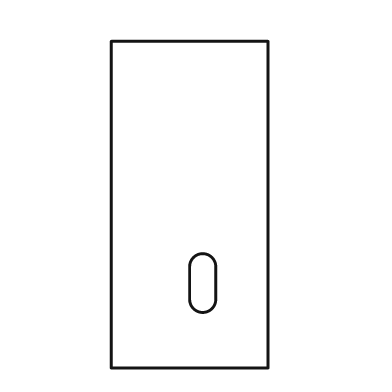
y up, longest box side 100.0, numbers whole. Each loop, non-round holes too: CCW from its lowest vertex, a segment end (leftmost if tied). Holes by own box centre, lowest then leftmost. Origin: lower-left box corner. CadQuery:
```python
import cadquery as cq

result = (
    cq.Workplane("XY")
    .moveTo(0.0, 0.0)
    .lineTo(48.0, 0.0)
    .lineTo(48.0, 100.0)
    .lineTo(0.0, 100.0)
    .close()
    .moveTo(24.0, 21.0)
    .threePointArc((28.0, 17.0), (32.0, 21.0))
    .lineTo(32.0, 31.0)
    .threePointArc((28.0, 35.0), (24.0, 31.0))
    .close()
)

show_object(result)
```